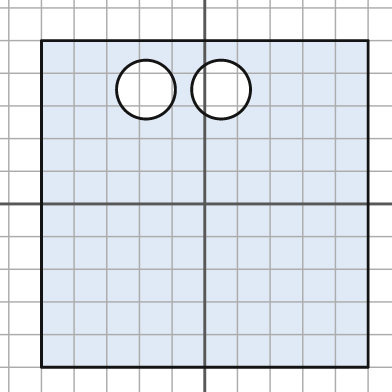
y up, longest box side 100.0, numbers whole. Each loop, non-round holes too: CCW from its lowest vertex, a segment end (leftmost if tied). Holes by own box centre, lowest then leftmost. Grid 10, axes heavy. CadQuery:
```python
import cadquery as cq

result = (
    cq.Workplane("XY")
    .moveTo(-50.0, -50.0)
    .lineTo(50.0, -50.0)
    .lineTo(50.0, 50.0)
    .lineTo(-50.0, 50.0)
    .close()
    .moveTo(-18.0, 35.0)
    .circle(9.0)
    .moveTo(5.0, 35.0)
    .circle(9.0)
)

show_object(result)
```